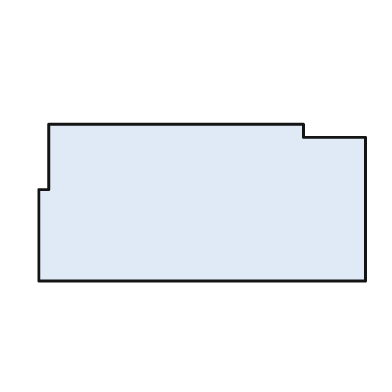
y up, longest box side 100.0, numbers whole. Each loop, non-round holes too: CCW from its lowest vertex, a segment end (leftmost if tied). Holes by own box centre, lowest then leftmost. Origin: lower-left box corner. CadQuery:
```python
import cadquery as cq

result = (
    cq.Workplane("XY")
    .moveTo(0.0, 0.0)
    .lineTo(100.0, 0.0)
    .lineTo(100.0, 44.0)
    .lineTo(81.0, 44.0)
    .lineTo(81.0, 48.0)
    .lineTo(3.0, 48.0)
    .lineTo(3.0, 28.0)
    .lineTo(0.0, 28.0)
    .close()
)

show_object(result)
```